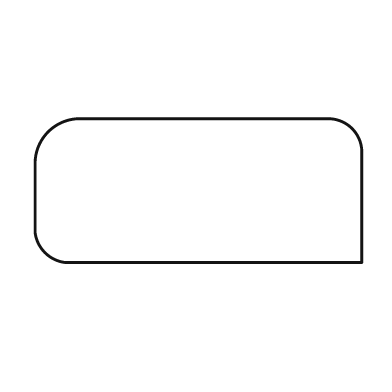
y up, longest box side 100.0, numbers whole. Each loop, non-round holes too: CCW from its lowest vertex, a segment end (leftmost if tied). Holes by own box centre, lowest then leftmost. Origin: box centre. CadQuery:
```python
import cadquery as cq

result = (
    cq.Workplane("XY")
    .moveTo(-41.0, -22.0)
    .lineTo(50.0, -22.0)
    .lineTo(50.0, 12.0)
    .threePointArc((47.0, 19.0), (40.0, 22.0))
    .lineTo(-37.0, 22.0)
    .threePointArc((-46.0, 18.0), (-50.0, 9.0))
    .lineTo(-50.0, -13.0)
    .threePointArc((-47.0, -19.0), (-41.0, -22.0))
    .close()
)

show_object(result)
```